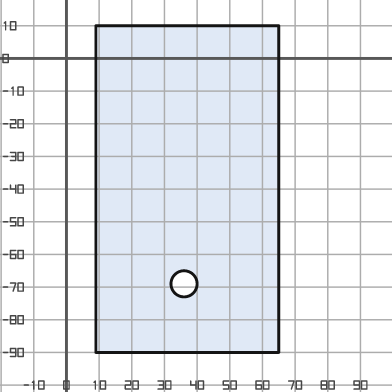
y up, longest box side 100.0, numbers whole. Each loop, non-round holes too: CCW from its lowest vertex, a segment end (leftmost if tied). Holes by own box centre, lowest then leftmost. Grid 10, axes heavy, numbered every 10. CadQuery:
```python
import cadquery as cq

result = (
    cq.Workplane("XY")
    .moveTo(9.0, -90.0)
    .lineTo(65.0, -90.0)
    .lineTo(65.0, 10.0)
    .lineTo(9.0, 10.0)
    .close()
    .moveTo(36.0, -69.0)
    .circle(4.0)
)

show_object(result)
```